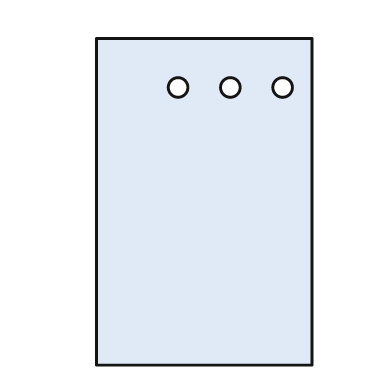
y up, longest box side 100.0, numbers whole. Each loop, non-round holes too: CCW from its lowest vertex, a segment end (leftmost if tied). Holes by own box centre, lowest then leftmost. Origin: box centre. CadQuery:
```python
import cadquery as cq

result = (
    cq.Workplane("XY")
    .moveTo(-33.0, -50.0)
    .lineTo(33.0, -50.0)
    .lineTo(33.0, 50.0)
    .lineTo(-33.0, 50.0)
    .close()
    .moveTo(-8.0, 35.0)
    .circle(3.0)
    .moveTo(8.0, 35.0)
    .circle(3.0)
    .moveTo(24.0, 35.0)
    .circle(3.0)
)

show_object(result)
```